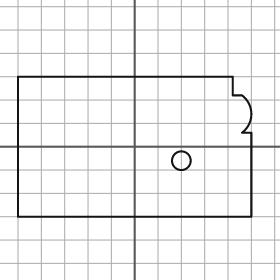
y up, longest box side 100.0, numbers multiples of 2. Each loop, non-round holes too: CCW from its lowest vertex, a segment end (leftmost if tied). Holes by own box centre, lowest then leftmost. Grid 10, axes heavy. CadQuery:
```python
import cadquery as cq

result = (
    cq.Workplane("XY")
    .moveTo(-50.0, -30.0)
    .lineTo(50.0, -30.0)
    .lineTo(50.0, 6.0)
    .lineTo(46.0, 6.0)
    .threePointArc((50.0, 14.0), (46.0, 22.0))
    .lineTo(42.0, 22.0)
    .lineTo(42.0, 30.0)
    .lineTo(-50.0, 30.0)
    .close()
    .moveTo(20.0, -6.0)
    .circle(4.0)
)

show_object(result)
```